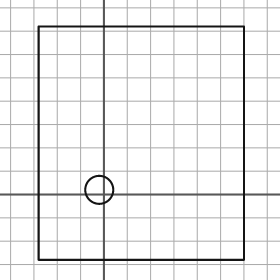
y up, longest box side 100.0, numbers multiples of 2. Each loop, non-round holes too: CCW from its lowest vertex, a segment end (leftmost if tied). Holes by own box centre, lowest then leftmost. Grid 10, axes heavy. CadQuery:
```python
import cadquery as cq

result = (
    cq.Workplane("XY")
    .moveTo(-28.0, -28.0)
    .lineTo(60.0, -28.0)
    .lineTo(60.0, 72.0)
    .lineTo(-28.0, 72.0)
    .close()
    .moveTo(-2.0, 2.0)
    .circle(6.0)
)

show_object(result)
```